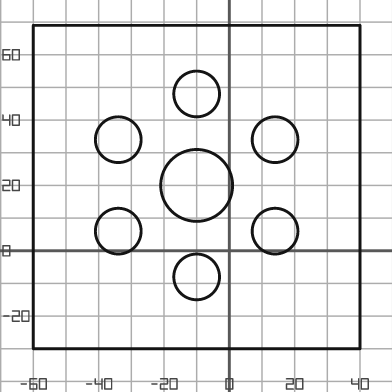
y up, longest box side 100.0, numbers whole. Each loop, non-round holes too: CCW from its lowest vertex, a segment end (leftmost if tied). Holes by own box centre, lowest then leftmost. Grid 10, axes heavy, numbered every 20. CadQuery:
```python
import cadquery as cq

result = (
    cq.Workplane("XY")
    .moveTo(-60.0, -30.0)
    .lineTo(40.0, -30.0)
    .lineTo(40.0, 69.0)
    .lineTo(-60.0, 69.0)
    .close()
    .moveTo(-10.0, -8.0)
    .circle(7.0)
    .moveTo(-34.0, 6.0)
    .circle(7.0)
    .moveTo(14.0, 6.0)
    .circle(7.0)
    .moveTo(-10.0, 20.0)
    .circle(11.0)
    .moveTo(-34.0, 34.0)
    .circle(7.0)
    .moveTo(14.0, 34.0)
    .circle(7.0)
    .moveTo(-10.0, 48.0)
    .circle(7.0)
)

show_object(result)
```